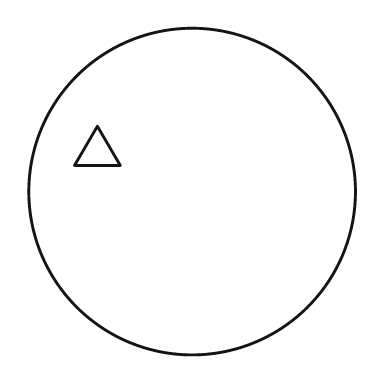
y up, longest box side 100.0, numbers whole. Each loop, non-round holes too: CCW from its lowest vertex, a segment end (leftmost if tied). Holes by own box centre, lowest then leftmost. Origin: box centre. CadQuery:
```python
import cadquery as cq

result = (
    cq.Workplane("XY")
    .moveTo(0.0, 0.0)
    .circle(50.0)
    .moveTo(-36.0, 8.0)
    .lineTo(-22.0, 8.0)
    .lineTo(-29.0, 20.0)
    .close()
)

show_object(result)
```